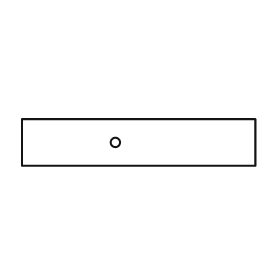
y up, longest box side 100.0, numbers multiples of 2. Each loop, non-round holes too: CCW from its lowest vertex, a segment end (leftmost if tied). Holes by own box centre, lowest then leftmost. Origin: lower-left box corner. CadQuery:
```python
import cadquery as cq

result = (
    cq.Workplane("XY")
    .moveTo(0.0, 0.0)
    .lineTo(100.0, 0.0)
    .lineTo(100.0, 20.0)
    .lineTo(0.0, 20.0)
    .close()
    .moveTo(40.0, 10.0)
    .circle(2.0)
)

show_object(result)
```